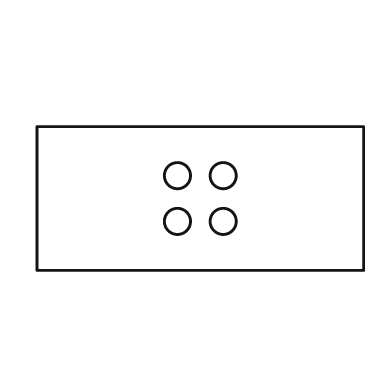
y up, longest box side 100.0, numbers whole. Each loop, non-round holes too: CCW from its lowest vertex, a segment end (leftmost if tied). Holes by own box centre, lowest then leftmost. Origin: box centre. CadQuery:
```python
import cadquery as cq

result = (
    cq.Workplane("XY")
    .moveTo(-50.0, -22.0)
    .lineTo(50.0, -22.0)
    .lineTo(50.0, 22.0)
    .lineTo(-50.0, 22.0)
    .close()
    .moveTo(-7.0, -7.0)
    .circle(4.0)
    .moveTo(7.0, -7.0)
    .circle(4.0)
    .moveTo(-7.0, 7.0)
    .circle(4.0)
    .moveTo(7.0, 7.0)
    .circle(4.0)
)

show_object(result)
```